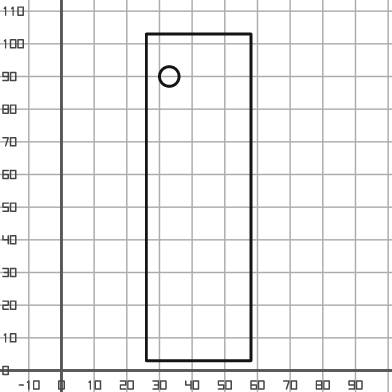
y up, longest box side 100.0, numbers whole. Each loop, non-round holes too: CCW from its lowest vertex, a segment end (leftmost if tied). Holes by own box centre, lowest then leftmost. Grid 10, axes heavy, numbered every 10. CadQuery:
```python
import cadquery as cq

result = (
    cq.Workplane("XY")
    .moveTo(26.0, 3.0)
    .lineTo(58.0, 3.0)
    .lineTo(58.0, 103.0)
    .lineTo(26.0, 103.0)
    .close()
    .moveTo(33.0, 90.0)
    .circle(3.0)
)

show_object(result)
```